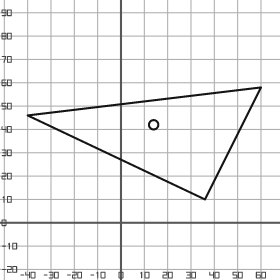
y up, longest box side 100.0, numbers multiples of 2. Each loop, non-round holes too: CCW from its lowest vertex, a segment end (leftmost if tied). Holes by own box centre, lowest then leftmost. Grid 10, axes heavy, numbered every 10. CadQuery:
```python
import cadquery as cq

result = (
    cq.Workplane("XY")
    .moveTo(36.0, 10.0)
    .lineTo(60.0, 58.0)
    .lineTo(-40.0, 46.0)
    .close()
    .moveTo(14.0, 42.0)
    .circle(2.0)
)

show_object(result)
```